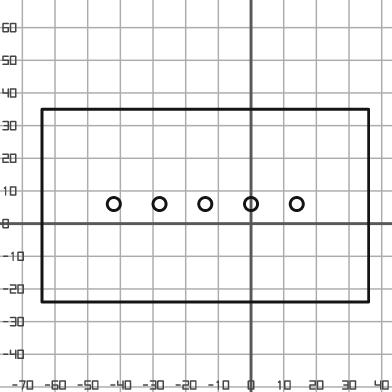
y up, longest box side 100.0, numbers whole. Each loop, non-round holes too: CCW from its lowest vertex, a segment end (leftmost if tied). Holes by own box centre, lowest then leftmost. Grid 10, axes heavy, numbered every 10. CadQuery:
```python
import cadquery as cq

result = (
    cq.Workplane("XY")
    .moveTo(-64.0, -24.0)
    .lineTo(36.0, -24.0)
    .lineTo(36.0, 35.0)
    .lineTo(-64.0, 35.0)
    .close()
    .moveTo(-42.0, 6.0)
    .circle(2.0)
    .moveTo(-28.0, 6.0)
    .circle(2.0)
    .moveTo(-14.0, 6.0)
    .circle(2.0)
    .moveTo(0.0, 6.0)
    .circle(2.0)
    .moveTo(14.0, 6.0)
    .circle(2.0)
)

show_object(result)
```